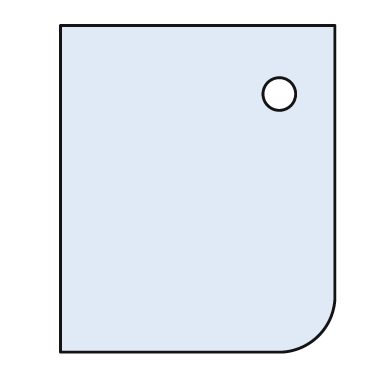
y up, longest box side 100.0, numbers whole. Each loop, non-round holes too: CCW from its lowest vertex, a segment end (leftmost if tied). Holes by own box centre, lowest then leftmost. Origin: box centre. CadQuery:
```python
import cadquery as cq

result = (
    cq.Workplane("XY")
    .moveTo(-42.0, -50.0)
    .lineTo(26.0, -50.0)
    .threePointArc((37.0, -45.0), (42.0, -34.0))
    .lineTo(42.0, 50.0)
    .lineTo(-42.0, 50.0)
    .close()
    .moveTo(25.0, 29.0)
    .circle(5.0)
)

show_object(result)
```